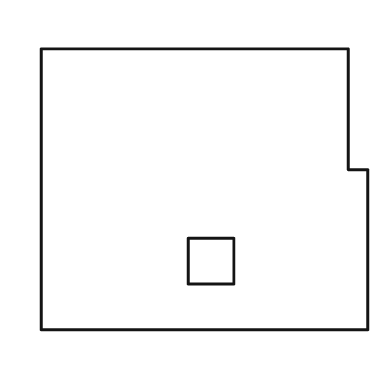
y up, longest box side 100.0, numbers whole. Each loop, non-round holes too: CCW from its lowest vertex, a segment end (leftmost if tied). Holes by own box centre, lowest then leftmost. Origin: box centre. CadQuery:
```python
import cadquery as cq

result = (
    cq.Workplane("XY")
    .moveTo(-50.0, -43.0)
    .lineTo(50.0, -43.0)
    .lineTo(50.0, 6.0)
    .lineTo(44.0, 6.0)
    .lineTo(44.0, 43.0)
    .lineTo(-50.0, 43.0)
    .close()
    .moveTo(-5.0, -29.0)
    .lineTo(9.0, -29.0)
    .lineTo(9.0, -15.0)
    .lineTo(-5.0, -15.0)
    .close()
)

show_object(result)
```